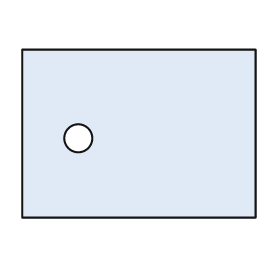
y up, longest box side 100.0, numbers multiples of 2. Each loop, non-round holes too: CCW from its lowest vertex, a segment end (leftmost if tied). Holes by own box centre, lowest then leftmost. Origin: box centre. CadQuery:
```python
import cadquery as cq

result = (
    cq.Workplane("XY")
    .moveTo(-50.0, -36.0)
    .lineTo(50.0, -36.0)
    .lineTo(50.0, 36.0)
    .lineTo(-50.0, 36.0)
    .close()
    .moveTo(-26.0, -2.0)
    .circle(6.0)
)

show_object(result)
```